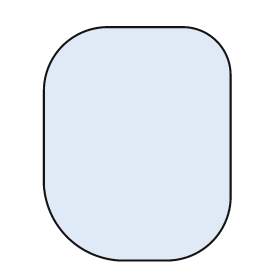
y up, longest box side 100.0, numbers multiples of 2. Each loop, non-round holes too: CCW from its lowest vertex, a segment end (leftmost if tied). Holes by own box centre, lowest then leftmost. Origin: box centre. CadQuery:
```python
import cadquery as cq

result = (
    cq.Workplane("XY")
    .moveTo(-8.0, -50.0)
    .lineTo(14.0, -50.0)
    .threePointArc((32.0, -42.0), (40.0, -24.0))
    .lineTo(40.0, 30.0)
    .threePointArc((34.0, 44.0), (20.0, 50.0))
    .lineTo(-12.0, 50.0)
    .threePointArc((-32.0, 42.0), (-40.0, 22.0))
    .lineTo(-40.0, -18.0)
    .threePointArc((-30.0, -40.0), (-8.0, -50.0))
    .close()
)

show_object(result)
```